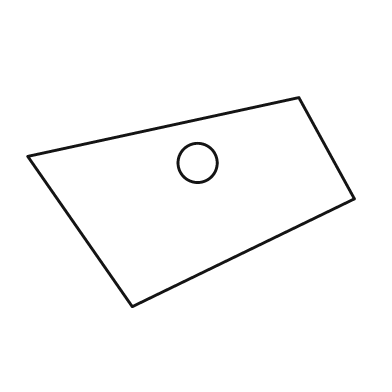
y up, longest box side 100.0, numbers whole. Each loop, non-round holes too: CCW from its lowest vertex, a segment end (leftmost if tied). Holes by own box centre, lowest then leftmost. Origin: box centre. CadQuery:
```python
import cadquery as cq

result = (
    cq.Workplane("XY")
    .moveTo(-18.0, -32.0)
    .lineTo(50.0, 1.0)
    .lineTo(33.0, 32.0)
    .lineTo(-50.0, 14.0)
    .close()
    .moveTo(2.0, 12.0)
    .circle(6.0)
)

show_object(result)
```